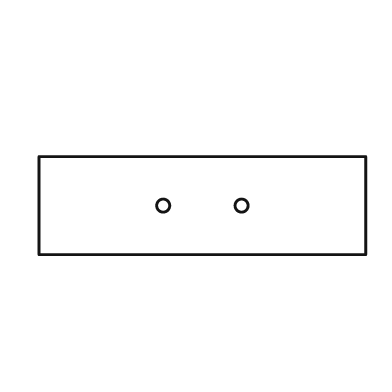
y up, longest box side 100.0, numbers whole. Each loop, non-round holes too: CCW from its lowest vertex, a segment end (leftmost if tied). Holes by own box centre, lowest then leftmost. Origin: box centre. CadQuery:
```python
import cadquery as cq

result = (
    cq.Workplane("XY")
    .moveTo(-50.0, -15.0)
    .lineTo(50.0, -15.0)
    .lineTo(50.0, 15.0)
    .lineTo(-50.0, 15.0)
    .close()
    .moveTo(-12.0, 0.0)
    .circle(2.0)
    .moveTo(12.0, 0.0)
    .circle(2.0)
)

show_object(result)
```